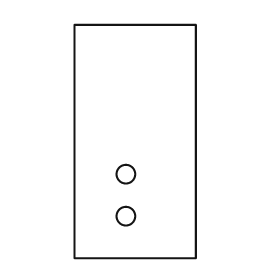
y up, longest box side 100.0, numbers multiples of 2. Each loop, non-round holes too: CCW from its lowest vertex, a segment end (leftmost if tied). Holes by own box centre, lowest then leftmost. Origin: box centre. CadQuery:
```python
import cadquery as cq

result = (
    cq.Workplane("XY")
    .moveTo(-26.0, -50.0)
    .lineTo(26.0, -50.0)
    .lineTo(26.0, 50.0)
    .lineTo(-26.0, 50.0)
    .close()
    .moveTo(-4.0, -32.0)
    .circle(4.0)
    .moveTo(-4.0, -14.0)
    .circle(4.0)
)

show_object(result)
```